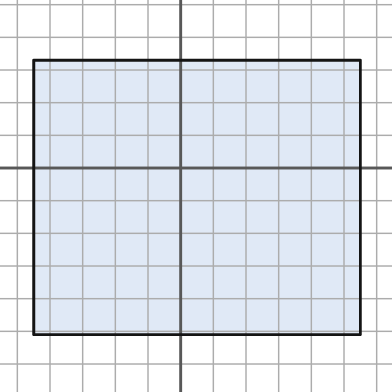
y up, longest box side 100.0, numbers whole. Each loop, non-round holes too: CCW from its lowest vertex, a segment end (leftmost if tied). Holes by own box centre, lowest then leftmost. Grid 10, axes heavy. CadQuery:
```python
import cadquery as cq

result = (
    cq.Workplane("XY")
    .moveTo(-45.0, -51.0)
    .lineTo(55.0, -51.0)
    .lineTo(55.0, 33.0)
    .lineTo(-45.0, 33.0)
    .close()
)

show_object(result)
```